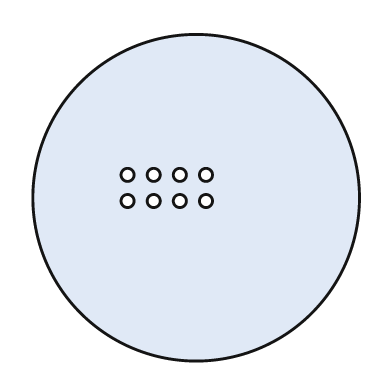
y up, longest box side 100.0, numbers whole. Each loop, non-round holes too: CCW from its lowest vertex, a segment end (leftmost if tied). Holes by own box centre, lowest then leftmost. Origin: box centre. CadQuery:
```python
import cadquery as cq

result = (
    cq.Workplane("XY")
    .moveTo(0.0, 0.0)
    .circle(50.0)
    .moveTo(-21.0, -1.0)
    .circle(2.0)
    .moveTo(-13.0, -1.0)
    .circle(2.0)
    .moveTo(-5.0, -1.0)
    .circle(2.0)
    .moveTo(3.0, -1.0)
    .circle(2.0)
    .moveTo(-21.0, 7.0)
    .circle(2.0)
    .moveTo(-13.0, 7.0)
    .circle(2.0)
    .moveTo(-5.0, 7.0)
    .circle(2.0)
    .moveTo(3.0, 7.0)
    .circle(2.0)
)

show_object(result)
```